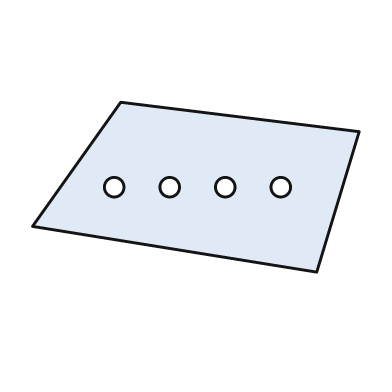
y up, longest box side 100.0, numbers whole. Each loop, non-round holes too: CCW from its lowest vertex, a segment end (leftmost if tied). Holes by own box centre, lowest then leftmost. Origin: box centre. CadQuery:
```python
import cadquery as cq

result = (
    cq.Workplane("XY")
    .moveTo(37.0, -26.0)
    .lineTo(50.0, 17.0)
    .lineTo(-23.0, 26.0)
    .lineTo(-50.0, -12.0)
    .close()
    .moveTo(-25.0, 0.0)
    .circle(3.0)
    .moveTo(-8.0, 0.0)
    .circle(3.0)
    .moveTo(9.0, 0.0)
    .circle(3.0)
    .moveTo(26.0, 0.0)
    .circle(3.0)
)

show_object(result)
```